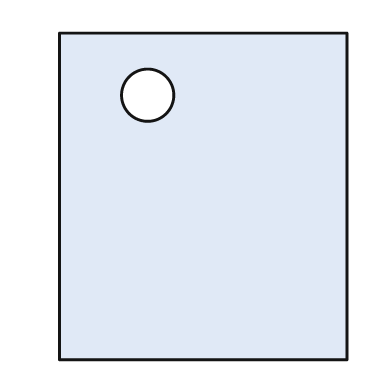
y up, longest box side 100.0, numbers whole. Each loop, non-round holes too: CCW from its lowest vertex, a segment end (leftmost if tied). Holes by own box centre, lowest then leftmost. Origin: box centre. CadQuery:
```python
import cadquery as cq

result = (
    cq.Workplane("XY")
    .moveTo(-44.0, -50.0)
    .lineTo(44.0, -50.0)
    .lineTo(44.0, 50.0)
    .lineTo(-44.0, 50.0)
    .close()
    .moveTo(-17.0, 31.0)
    .circle(8.0)
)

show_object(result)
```